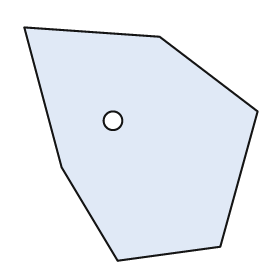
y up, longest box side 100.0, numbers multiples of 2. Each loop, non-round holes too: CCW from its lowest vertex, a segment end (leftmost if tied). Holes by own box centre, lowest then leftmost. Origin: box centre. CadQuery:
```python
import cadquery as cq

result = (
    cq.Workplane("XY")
    .moveTo(-10.0, -50.0)
    .lineTo(34.0, -44.0)
    .lineTo(50.0, 14.0)
    .lineTo(8.0, 46.0)
    .lineTo(-50.0, 50.0)
    .lineTo(-34.0, -10.0)
    .close()
    .moveTo(-12.0, 10.0)
    .circle(4.0)
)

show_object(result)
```